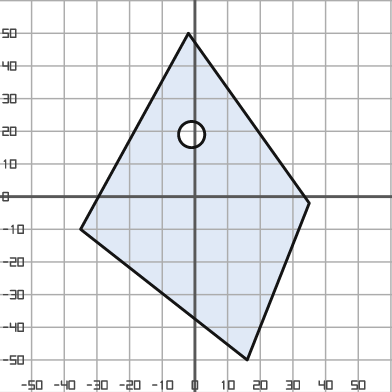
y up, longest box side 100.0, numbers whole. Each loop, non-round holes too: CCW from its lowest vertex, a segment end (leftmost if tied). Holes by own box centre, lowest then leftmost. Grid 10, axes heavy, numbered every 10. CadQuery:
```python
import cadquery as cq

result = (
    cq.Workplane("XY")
    .moveTo(16.0, -50.0)
    .lineTo(35.0, -2.0)
    .lineTo(-2.0, 50.0)
    .lineTo(-35.0, -10.0)
    .close()
    .moveTo(-1.0, 19.0)
    .circle(4.0)
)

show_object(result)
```